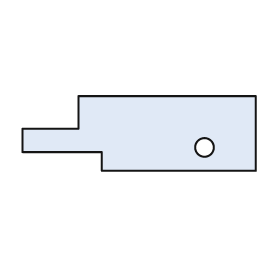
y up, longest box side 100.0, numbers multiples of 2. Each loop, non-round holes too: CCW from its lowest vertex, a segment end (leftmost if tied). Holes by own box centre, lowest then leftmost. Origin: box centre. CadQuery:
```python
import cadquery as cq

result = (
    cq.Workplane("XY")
    .moveTo(-16.0, -16.0)
    .lineTo(50.0, -16.0)
    .lineTo(50.0, 16.0)
    .lineTo(-26.0, 16.0)
    .lineTo(-26.0, 2.0)
    .lineTo(-50.0, 2.0)
    .lineTo(-50.0, -8.0)
    .lineTo(-16.0, -8.0)
    .close()
    .moveTo(28.0, -6.0)
    .circle(4.0)
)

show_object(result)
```